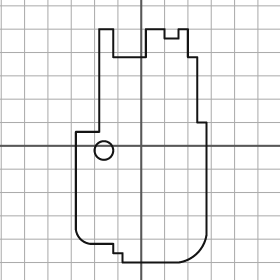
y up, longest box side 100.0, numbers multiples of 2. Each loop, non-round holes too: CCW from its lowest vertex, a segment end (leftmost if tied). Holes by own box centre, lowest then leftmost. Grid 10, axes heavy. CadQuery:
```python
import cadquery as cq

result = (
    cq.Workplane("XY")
    .moveTo(-8.0, -50.0)
    .lineTo(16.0, -50.0)
    .threePointArc((24.0, -46.0), (28.0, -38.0))
    .lineTo(28.0, 10.0)
    .lineTo(24.0, 10.0)
    .lineTo(24.0, 38.0)
    .lineTo(20.0, 38.0)
    .lineTo(20.0, 50.0)
    .lineTo(16.0, 50.0)
    .lineTo(16.0, 46.0)
    .lineTo(10.0, 46.0)
    .lineTo(10.0, 50.0)
    .lineTo(2.0, 50.0)
    .lineTo(2.0, 38.0)
    .lineTo(-12.0, 38.0)
    .lineTo(-12.0, 50.0)
    .lineTo(-18.0, 50.0)
    .lineTo(-18.0, 6.0)
    .lineTo(-28.0, 6.0)
    .lineTo(-28.0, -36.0)
    .threePointArc((-26.0, -40.0), (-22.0, -42.0))
    .lineTo(-12.0, -42.0)
    .lineTo(-12.0, -46.0)
    .lineTo(-8.0, -46.0)
    .close()
    .moveTo(-16.0, -2.0)
    .circle(4.0)
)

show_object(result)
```